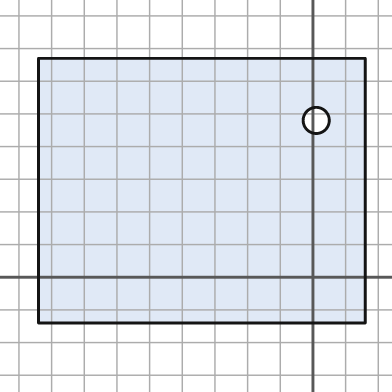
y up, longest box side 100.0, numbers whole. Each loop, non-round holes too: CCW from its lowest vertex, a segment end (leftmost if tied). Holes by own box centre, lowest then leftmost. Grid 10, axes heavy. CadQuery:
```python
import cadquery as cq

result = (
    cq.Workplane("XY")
    .moveTo(-84.0, -14.0)
    .lineTo(16.0, -14.0)
    .lineTo(16.0, 67.0)
    .lineTo(-84.0, 67.0)
    .close()
    .moveTo(1.0, 48.0)
    .circle(4.0)
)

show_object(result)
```